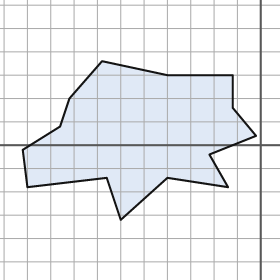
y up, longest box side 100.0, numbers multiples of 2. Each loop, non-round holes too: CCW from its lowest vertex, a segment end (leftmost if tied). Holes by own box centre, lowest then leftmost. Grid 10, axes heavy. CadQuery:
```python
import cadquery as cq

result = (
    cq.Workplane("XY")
    .moveTo(-60.0, -32.0)
    .lineTo(-40.0, -14.0)
    .lineTo(-14.0, -18.0)
    .lineTo(-22.0, -4.0)
    .lineTo(-2.0, 4.0)
    .lineTo(-12.0, 16.0)
    .lineTo(-12.0, 30.0)
    .lineTo(-40.0, 30.0)
    .lineTo(-68.0, 36.0)
    .lineTo(-82.0, 20.0)
    .lineTo(-86.0, 8.0)
    .lineTo(-102.0, -2.0)
    .lineTo(-100.0, -18.0)
    .lineTo(-66.0, -14.0)
    .close()
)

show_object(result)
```